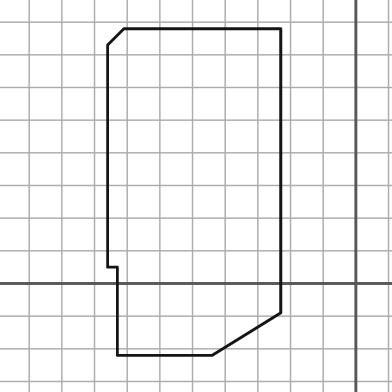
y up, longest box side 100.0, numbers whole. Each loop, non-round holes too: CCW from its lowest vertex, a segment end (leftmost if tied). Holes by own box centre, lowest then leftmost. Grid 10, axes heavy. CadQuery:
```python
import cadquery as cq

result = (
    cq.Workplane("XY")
    .moveTo(-73.0, -22.0)
    .lineTo(-44.0, -22.0)
    .lineTo(-23.0, -9.0)
    .lineTo(-23.0, 78.0)
    .lineTo(-71.0, 78.0)
    .lineTo(-76.0, 73.0)
    .lineTo(-76.0, 5.0)
    .lineTo(-73.0, 5.0)
    .close()
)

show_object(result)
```